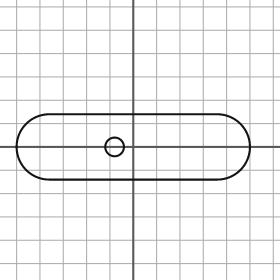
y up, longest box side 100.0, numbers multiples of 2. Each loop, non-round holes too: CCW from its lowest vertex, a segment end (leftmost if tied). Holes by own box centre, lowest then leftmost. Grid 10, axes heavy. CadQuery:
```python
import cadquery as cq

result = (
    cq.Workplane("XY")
    .moveTo(-36.0, -14.0)
    .lineTo(36.0, -14.0)
    .threePointArc((50.0, 0.0), (36.0, 14.0))
    .lineTo(-36.0, 14.0)
    .threePointArc((-50.0, 0.0), (-36.0, -14.0))
    .close()
    .moveTo(-8.0, 0.0)
    .circle(4.0)
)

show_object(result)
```